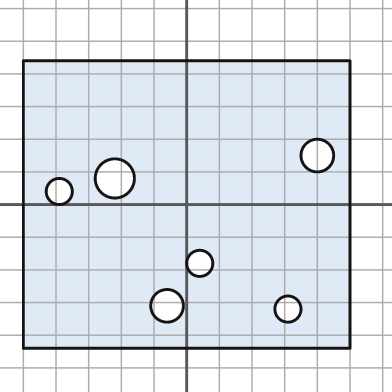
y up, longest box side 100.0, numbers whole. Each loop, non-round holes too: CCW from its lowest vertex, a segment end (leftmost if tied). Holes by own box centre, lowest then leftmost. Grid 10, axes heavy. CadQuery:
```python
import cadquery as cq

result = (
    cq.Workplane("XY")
    .moveTo(-50.0, -44.0)
    .lineTo(50.0, -44.0)
    .lineTo(50.0, 44.0)
    .lineTo(-50.0, 44.0)
    .close()
    .moveTo(31.0, -32.0)
    .circle(4.0)
    .moveTo(-6.0, -31.0)
    .circle(5.0)
    .moveTo(4.0, -18.0)
    .circle(4.0)
    .moveTo(-39.0, 4.0)
    .circle(4.0)
    .moveTo(-22.0, 8.0)
    .circle(6.0)
    .moveTo(40.0, 15.0)
    .circle(5.0)
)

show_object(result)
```